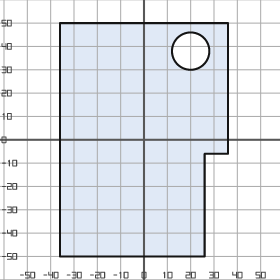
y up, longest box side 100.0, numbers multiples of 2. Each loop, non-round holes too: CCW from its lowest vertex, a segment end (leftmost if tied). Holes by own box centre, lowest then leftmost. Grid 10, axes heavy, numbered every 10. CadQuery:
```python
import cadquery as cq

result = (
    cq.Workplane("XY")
    .moveTo(-36.0, -50.0)
    .lineTo(26.0, -50.0)
    .lineTo(26.0, -6.0)
    .lineTo(36.0, -6.0)
    .lineTo(36.0, 50.0)
    .lineTo(-36.0, 50.0)
    .close()
    .moveTo(20.0, 38.0)
    .circle(8.0)
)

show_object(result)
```